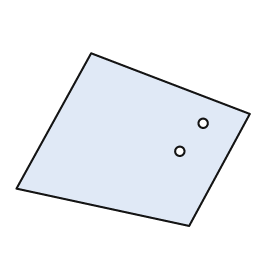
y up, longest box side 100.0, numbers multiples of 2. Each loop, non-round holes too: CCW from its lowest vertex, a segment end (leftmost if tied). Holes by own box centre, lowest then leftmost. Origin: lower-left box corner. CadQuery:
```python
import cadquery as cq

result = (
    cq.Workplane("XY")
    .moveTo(74.0, 0.0)
    .lineTo(100.0, 48.0)
    .lineTo(32.0, 74.0)
    .lineTo(0.0, 16.0)
    .close()
    .moveTo(70.0, 32.0)
    .circle(2.0)
    .moveTo(80.0, 44.0)
    .circle(2.0)
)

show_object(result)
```